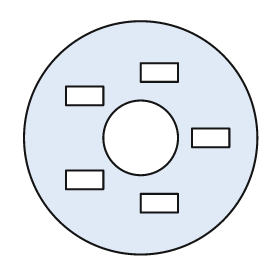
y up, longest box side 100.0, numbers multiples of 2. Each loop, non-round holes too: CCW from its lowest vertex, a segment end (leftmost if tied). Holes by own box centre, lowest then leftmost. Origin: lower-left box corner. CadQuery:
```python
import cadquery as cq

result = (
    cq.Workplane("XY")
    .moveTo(50.0, 50.0)
    .circle(50.0)
    .moveTo(50.0, 18.0)
    .lineTo(66.0, 18.0)
    .lineTo(66.0, 26.0)
    .lineTo(50.0, 26.0)
    .close()
    .moveTo(18.0, 28.0)
    .lineTo(34.0, 28.0)
    .lineTo(34.0, 36.0)
    .lineTo(18.0, 36.0)
    .close()
    .moveTo(50.0, 50.0)
    .circle(16.0)
    .moveTo(72.0, 46.0)
    .lineTo(88.0, 46.0)
    .lineTo(88.0, 54.0)
    .lineTo(72.0, 54.0)
    .close()
    .moveTo(18.0, 64.0)
    .lineTo(34.0, 64.0)
    .lineTo(34.0, 72.0)
    .lineTo(18.0, 72.0)
    .close()
    .moveTo(50.0, 74.0)
    .lineTo(66.0, 74.0)
    .lineTo(66.0, 82.0)
    .lineTo(50.0, 82.0)
    .close()
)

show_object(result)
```